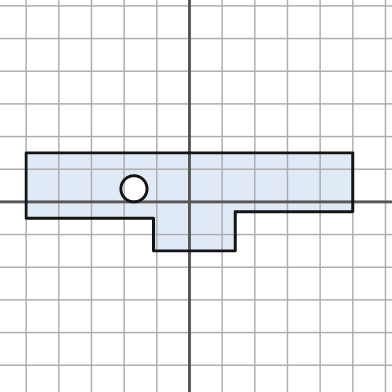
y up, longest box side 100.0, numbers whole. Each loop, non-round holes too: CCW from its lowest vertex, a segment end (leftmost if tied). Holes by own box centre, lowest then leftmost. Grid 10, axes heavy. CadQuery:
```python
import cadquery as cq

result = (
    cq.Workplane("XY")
    .moveTo(-11.0, -15.0)
    .lineTo(14.0, -15.0)
    .lineTo(14.0, -3.0)
    .lineTo(50.0, -3.0)
    .lineTo(50.0, 15.0)
    .lineTo(-50.0, 15.0)
    .lineTo(-50.0, -5.0)
    .lineTo(-11.0, -5.0)
    .close()
    .moveTo(-17.0, 4.0)
    .circle(4.0)
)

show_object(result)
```